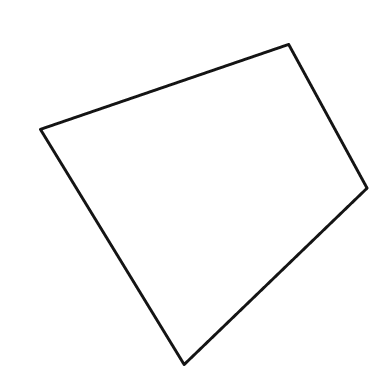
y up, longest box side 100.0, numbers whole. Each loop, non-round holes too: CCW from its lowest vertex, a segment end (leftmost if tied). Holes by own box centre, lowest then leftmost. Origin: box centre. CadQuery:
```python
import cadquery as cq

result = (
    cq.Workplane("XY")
    .moveTo(-6.0, -49.0)
    .lineTo(50.0, 5.0)
    .lineTo(26.0, 49.0)
    .lineTo(-50.0, 23.0)
    .close()
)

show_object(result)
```